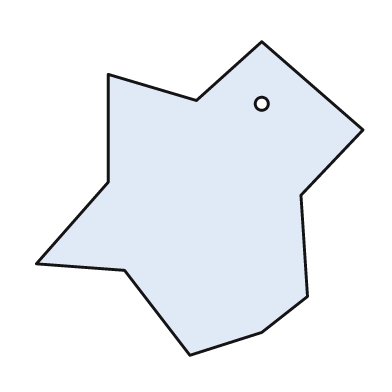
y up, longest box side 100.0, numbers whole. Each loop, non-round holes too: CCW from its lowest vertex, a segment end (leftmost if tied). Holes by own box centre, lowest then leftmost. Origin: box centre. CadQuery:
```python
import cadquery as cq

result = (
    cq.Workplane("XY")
    .moveTo(-3.0, -48.0)
    .lineTo(19.0, -41.0)
    .lineTo(33.0, -30.0)
    .lineTo(31.0, 1.0)
    .lineTo(50.0, 21.0)
    .lineTo(19.0, 48.0)
    .lineTo(-1.0, 30.0)
    .lineTo(-28.0, 38.0)
    .lineTo(-28.0, 5.0)
    .lineTo(-50.0, -20.0)
    .lineTo(-23.0, -22.0)
    .close()
    .moveTo(19.0, 29.0)
    .circle(2.0)
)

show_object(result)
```